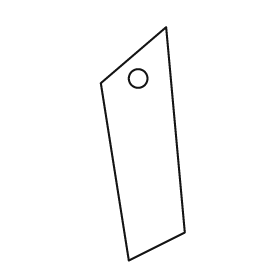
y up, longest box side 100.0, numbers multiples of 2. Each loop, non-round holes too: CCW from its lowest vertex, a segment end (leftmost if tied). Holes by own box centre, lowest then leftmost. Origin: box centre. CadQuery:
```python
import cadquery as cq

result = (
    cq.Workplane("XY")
    .moveTo(-6.0, -50.0)
    .lineTo(18.0, -38.0)
    .lineTo(10.0, 50.0)
    .lineTo(-18.0, 26.0)
    .close()
    .moveTo(-2.0, 28.0)
    .circle(4.0)
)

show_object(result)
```